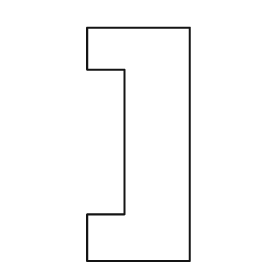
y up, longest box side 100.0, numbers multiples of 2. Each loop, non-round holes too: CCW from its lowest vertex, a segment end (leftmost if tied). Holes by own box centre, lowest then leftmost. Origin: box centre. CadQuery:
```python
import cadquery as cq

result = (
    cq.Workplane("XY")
    .moveTo(-22.0, -50.0)
    .lineTo(22.0, -50.0)
    .lineTo(22.0, 50.0)
    .lineTo(-22.0, 50.0)
    .lineTo(-22.0, 32.0)
    .lineTo(-6.0, 32.0)
    .lineTo(-6.0, -30.0)
    .lineTo(-22.0, -30.0)
    .close()
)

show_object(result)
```